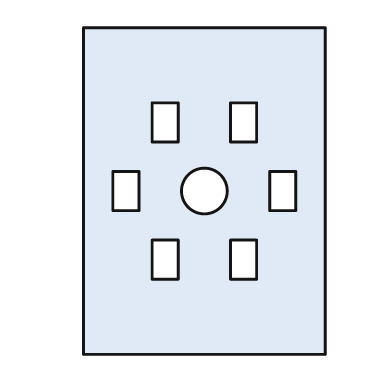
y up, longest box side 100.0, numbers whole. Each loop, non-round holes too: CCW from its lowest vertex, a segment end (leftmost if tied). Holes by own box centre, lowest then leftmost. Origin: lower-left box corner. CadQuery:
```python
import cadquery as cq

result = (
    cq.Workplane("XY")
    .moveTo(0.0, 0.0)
    .lineTo(74.0, 0.0)
    .lineTo(74.0, 100.0)
    .lineTo(0.0, 100.0)
    .close()
    .moveTo(21.0, 23.0)
    .lineTo(29.0, 23.0)
    .lineTo(29.0, 35.0)
    .lineTo(21.0, 35.0)
    .close()
    .moveTo(45.0, 23.0)
    .lineTo(53.0, 23.0)
    .lineTo(53.0, 35.0)
    .lineTo(45.0, 35.0)
    .close()
    .moveTo(9.0, 44.0)
    .lineTo(17.0, 44.0)
    .lineTo(17.0, 56.0)
    .lineTo(9.0, 56.0)
    .close()
    .moveTo(37.0, 50.0)
    .circle(7.0)
    .moveTo(57.0, 44.0)
    .lineTo(65.0, 44.0)
    .lineTo(65.0, 56.0)
    .lineTo(57.0, 56.0)
    .close()
    .moveTo(21.0, 65.0)
    .lineTo(29.0, 65.0)
    .lineTo(29.0, 77.0)
    .lineTo(21.0, 77.0)
    .close()
    .moveTo(45.0, 65.0)
    .lineTo(53.0, 65.0)
    .lineTo(53.0, 77.0)
    .lineTo(45.0, 77.0)
    .close()
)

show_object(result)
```